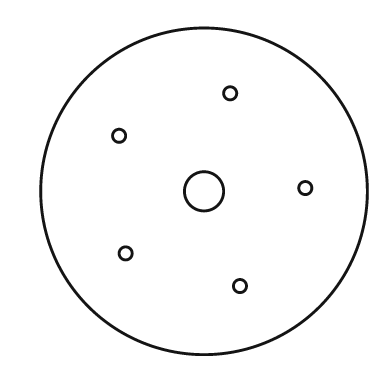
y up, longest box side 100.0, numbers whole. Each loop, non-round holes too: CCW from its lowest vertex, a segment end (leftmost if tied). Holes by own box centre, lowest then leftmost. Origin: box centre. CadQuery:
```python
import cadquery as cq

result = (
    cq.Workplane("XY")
    .moveTo(0.0, 0.0)
    .circle(50.0)
    .moveTo(11.0, -29.0)
    .circle(2.0)
    .moveTo(-24.0, -19.0)
    .circle(2.0)
    .moveTo(0.0, 0.0)
    .circle(6.0)
    .moveTo(31.0, 1.0)
    .circle(2.0)
    .moveTo(-26.0, 17.0)
    .circle(2.0)
    .moveTo(8.0, 30.0)
    .circle(2.0)
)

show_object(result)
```